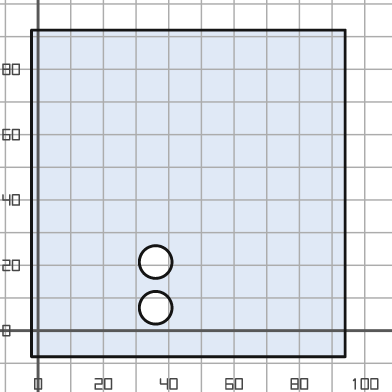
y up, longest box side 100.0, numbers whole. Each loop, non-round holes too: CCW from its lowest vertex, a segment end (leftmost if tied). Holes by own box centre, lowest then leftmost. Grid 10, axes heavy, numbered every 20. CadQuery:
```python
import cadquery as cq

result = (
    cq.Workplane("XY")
    .moveTo(-2.0, -8.0)
    .lineTo(94.0, -8.0)
    .lineTo(94.0, 92.0)
    .lineTo(-2.0, 92.0)
    .close()
    .moveTo(36.0, 7.0)
    .circle(5.0)
    .moveTo(36.0, 21.0)
    .circle(5.0)
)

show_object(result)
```